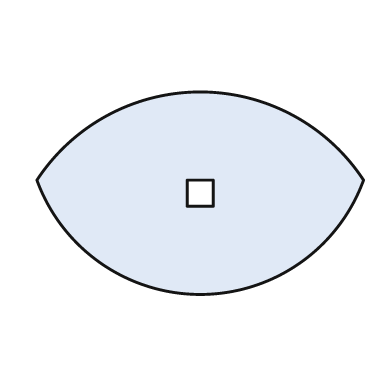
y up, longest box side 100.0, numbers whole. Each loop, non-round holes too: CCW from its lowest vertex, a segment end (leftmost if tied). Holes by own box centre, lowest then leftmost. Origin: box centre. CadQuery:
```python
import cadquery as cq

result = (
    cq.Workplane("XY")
    .moveTo(-50.0, 4.0)
    .threePointArc((0.0, -31.0), (50.0, 4.0))
    .threePointArc((0.0, 31.0), (-50.0, 4.0))
    .close()
    .moveTo(-4.0, -4.0)
    .lineTo(4.0, -4.0)
    .lineTo(4.0, 4.0)
    .lineTo(-4.0, 4.0)
    .close()
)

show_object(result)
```